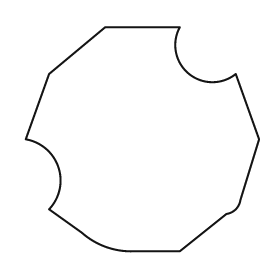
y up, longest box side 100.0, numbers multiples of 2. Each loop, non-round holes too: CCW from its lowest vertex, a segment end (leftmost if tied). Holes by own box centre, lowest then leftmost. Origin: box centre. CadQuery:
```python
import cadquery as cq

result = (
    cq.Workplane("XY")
    .moveTo(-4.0, -48.0)
    .lineTo(16.0, -48.0)
    .lineTo(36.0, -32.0)
    .threePointArc((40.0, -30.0), (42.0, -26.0))
    .lineTo(50.0, 0.0)
    .lineTo(40.0, 28.0)
    .threePointArc((20.0, 28.0), (16.0, 48.0))
    .lineTo(-16.0, 48.0)
    .lineTo(-40.0, 28.0)
    .lineTo(-50.0, 0.0)
    .threePointArc((-36.0, -12.0), (-40.0, -30.0))
    .lineTo(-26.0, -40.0)
    .threePointArc((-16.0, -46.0), (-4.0, -48.0))
    .close()
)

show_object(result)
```